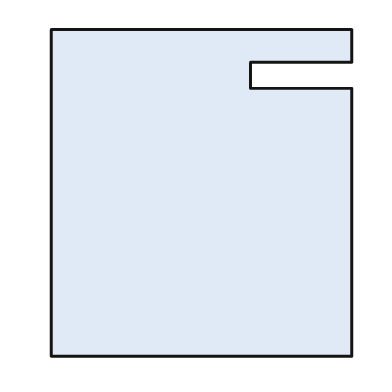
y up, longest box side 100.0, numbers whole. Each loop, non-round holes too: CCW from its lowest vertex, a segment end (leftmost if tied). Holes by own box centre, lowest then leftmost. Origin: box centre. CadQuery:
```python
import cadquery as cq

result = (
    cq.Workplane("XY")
    .moveTo(-46.0, -50.0)
    .lineTo(46.0, -50.0)
    .lineTo(46.0, 32.0)
    .lineTo(15.0, 32.0)
    .lineTo(15.0, 40.0)
    .lineTo(46.0, 40.0)
    .lineTo(46.0, 50.0)
    .lineTo(-46.0, 50.0)
    .close()
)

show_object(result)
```